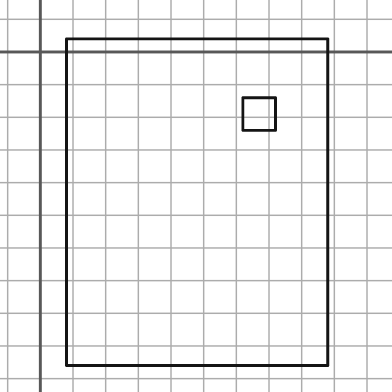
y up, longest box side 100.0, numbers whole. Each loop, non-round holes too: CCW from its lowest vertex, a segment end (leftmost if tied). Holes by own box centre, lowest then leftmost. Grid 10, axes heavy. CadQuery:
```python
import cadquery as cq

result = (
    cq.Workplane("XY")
    .moveTo(8.0, -96.0)
    .lineTo(88.0, -96.0)
    .lineTo(88.0, 4.0)
    .lineTo(8.0, 4.0)
    .close()
    .moveTo(62.0, -24.0)
    .lineTo(72.0, -24.0)
    .lineTo(72.0, -14.0)
    .lineTo(62.0, -14.0)
    .close()
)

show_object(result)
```